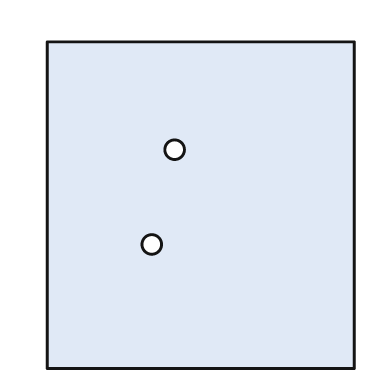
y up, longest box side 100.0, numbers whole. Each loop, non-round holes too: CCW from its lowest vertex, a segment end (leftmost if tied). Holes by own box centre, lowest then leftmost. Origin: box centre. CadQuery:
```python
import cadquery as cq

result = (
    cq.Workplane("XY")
    .moveTo(-47.0, -50.0)
    .lineTo(47.0, -50.0)
    .lineTo(47.0, 50.0)
    .lineTo(-47.0, 50.0)
    .close()
    .moveTo(-15.0, -12.0)
    .circle(3.0)
    .moveTo(-8.0, 17.0)
    .circle(3.0)
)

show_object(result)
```